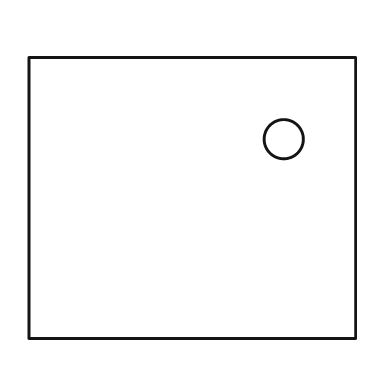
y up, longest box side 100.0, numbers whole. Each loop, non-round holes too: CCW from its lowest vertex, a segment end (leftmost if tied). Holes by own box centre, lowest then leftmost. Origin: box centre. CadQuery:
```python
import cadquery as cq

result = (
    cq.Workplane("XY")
    .moveTo(-50.0, -43.0)
    .lineTo(50.0, -43.0)
    .lineTo(50.0, 43.0)
    .lineTo(-50.0, 43.0)
    .close()
    .moveTo(28.0, 18.0)
    .circle(6.0)
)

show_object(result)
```